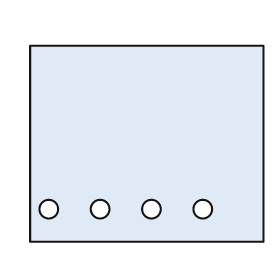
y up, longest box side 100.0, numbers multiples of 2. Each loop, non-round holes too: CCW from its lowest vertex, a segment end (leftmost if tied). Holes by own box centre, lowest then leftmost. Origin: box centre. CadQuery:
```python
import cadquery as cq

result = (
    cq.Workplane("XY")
    .moveTo(-50.0, -42.0)
    .lineTo(50.0, -42.0)
    .lineTo(50.0, 42.0)
    .lineTo(-50.0, 42.0)
    .close()
    .moveTo(-42.0, -28.0)
    .circle(4.0)
    .moveTo(-20.0, -28.0)
    .circle(4.0)
    .moveTo(2.0, -28.0)
    .circle(4.0)
    .moveTo(24.0, -28.0)
    .circle(4.0)
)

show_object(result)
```